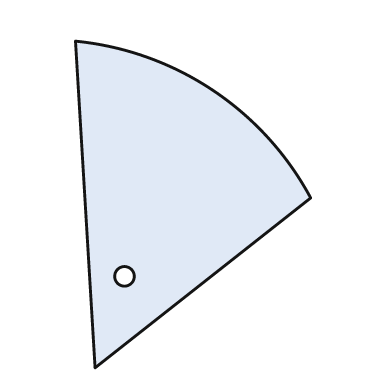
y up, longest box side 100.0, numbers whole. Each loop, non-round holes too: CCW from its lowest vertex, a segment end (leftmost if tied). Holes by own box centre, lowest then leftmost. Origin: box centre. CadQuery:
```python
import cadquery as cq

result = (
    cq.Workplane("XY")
    .moveTo(-30.0, -50.0)
    .lineTo(36.0, 2.0)
    .threePointArc((6.0, 35.0), (-36.0, 50.0))
    .close()
    .moveTo(-21.0, -22.0)
    .circle(3.0)
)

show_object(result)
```